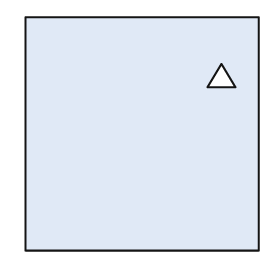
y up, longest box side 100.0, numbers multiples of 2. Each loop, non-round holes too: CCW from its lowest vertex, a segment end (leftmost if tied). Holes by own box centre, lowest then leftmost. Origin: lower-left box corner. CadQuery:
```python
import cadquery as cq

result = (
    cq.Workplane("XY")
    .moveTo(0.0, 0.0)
    .lineTo(100.0, 0.0)
    .lineTo(100.0, 100.0)
    .lineTo(0.0, 100.0)
    .close()
    .moveTo(78.0, 70.0)
    .lineTo(90.0, 70.0)
    .lineTo(84.0, 80.0)
    .close()
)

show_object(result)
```